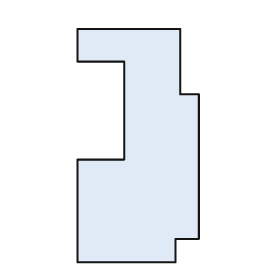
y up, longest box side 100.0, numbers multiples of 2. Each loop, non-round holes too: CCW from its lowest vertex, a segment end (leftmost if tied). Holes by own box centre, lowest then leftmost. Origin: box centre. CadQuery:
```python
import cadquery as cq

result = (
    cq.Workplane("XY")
    .moveTo(-26.0, -50.0)
    .lineTo(16.0, -50.0)
    .lineTo(16.0, -40.0)
    .lineTo(26.0, -40.0)
    .lineTo(26.0, 22.0)
    .lineTo(18.0, 22.0)
    .lineTo(18.0, 50.0)
    .lineTo(-26.0, 50.0)
    .lineTo(-26.0, 36.0)
    .lineTo(-6.0, 36.0)
    .lineTo(-6.0, -6.0)
    .lineTo(-26.0, -6.0)
    .close()
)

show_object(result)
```